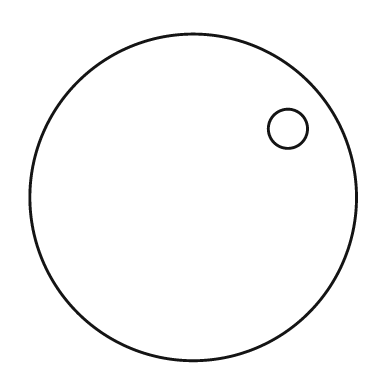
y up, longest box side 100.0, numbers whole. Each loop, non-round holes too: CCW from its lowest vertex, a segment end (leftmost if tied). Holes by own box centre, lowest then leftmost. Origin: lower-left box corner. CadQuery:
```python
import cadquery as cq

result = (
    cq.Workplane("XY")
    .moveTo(50.0, 50.0)
    .circle(50.0)
    .moveTo(79.0, 71.0)
    .circle(6.0)
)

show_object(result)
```